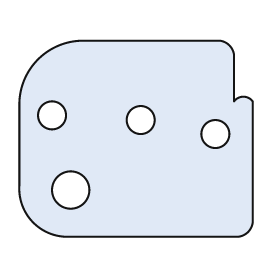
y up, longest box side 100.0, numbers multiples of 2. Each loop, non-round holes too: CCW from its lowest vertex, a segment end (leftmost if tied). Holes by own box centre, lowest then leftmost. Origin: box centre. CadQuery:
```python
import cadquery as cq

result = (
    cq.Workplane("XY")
    .moveTo(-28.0, -42.0)
    .lineTo(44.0, -42.0)
    .threePointArc((48.0, -40.0), (50.0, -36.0))
    .lineTo(50.0, 16.0)
    .threePointArc((46.0, 18.0), (42.0, 16.0))
    .lineTo(42.0, 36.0)
    .threePointArc((40.0, 40.0), (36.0, 42.0))
    .lineTo(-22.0, 42.0)
    .threePointArc((-42.0, 34.0), (-50.0, 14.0))
    .lineTo(-50.0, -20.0)
    .threePointArc((-44.0, -36.0), (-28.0, -42.0))
    .close()
    .moveTo(-28.0, -22.0)
    .circle(8.0)
    .moveTo(34.0, 2.0)
    .circle(6.0)
    .moveTo(2.0, 8.0)
    .circle(6.0)
    .moveTo(-36.0, 10.0)
    .circle(6.0)
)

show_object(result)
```